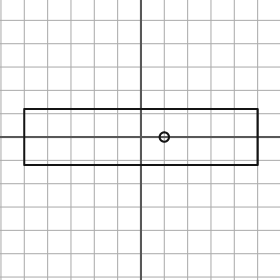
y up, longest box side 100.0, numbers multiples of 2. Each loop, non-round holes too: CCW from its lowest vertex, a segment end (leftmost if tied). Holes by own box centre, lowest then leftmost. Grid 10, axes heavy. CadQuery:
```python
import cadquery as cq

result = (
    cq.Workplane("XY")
    .moveTo(-50.0, -12.0)
    .lineTo(50.0, -12.0)
    .lineTo(50.0, 12.0)
    .lineTo(-50.0, 12.0)
    .close()
    .moveTo(10.0, 0.0)
    .circle(2.0)
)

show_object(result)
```